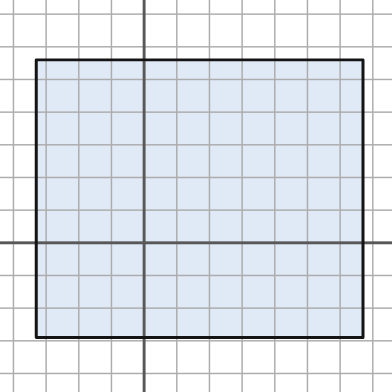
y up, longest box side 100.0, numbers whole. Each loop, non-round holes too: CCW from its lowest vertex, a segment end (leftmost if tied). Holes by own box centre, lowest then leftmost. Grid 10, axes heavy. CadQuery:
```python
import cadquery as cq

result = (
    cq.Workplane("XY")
    .moveTo(-33.0, -29.0)
    .lineTo(67.0, -29.0)
    .lineTo(67.0, 56.0)
    .lineTo(-33.0, 56.0)
    .close()
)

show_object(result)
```